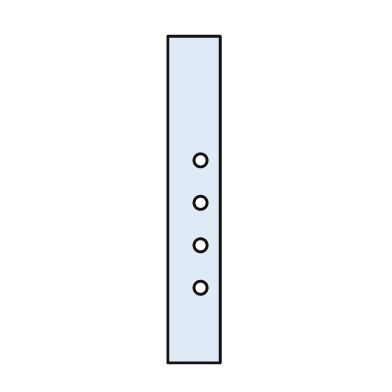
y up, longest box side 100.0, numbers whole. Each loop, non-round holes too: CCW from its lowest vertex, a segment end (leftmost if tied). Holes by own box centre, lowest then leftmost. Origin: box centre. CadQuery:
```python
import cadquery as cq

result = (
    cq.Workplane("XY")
    .moveTo(-8.0, -50.0)
    .lineTo(8.0, -50.0)
    .lineTo(8.0, 50.0)
    .lineTo(-8.0, 50.0)
    .close()
    .moveTo(2.0, -27.0)
    .circle(2.0)
    .moveTo(2.0, -14.0)
    .circle(2.0)
    .moveTo(2.0, -1.0)
    .circle(2.0)
    .moveTo(2.0, 12.0)
    .circle(2.0)
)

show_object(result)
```